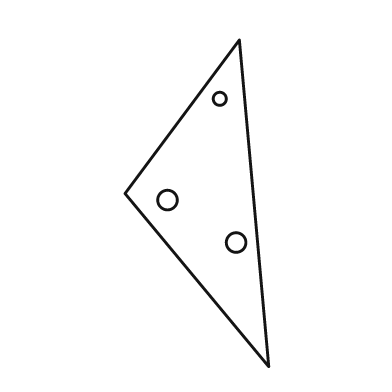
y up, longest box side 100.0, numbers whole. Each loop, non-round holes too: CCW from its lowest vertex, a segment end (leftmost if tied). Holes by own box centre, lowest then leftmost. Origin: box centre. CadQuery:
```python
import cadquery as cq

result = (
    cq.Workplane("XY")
    .moveTo(22.0, -50.0)
    .lineTo(13.0, 50.0)
    .lineTo(-22.0, 3.0)
    .close()
    .moveTo(12.0, -12.0)
    .circle(3.0)
    .moveTo(-9.0, 1.0)
    .circle(3.0)
    .moveTo(7.0, 32.0)
    .circle(2.0)
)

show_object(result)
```